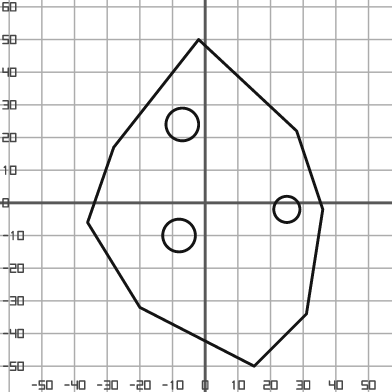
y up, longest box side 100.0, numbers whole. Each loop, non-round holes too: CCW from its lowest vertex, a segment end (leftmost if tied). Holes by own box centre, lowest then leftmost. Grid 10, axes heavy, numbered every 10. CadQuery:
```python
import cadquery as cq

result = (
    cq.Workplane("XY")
    .moveTo(15.0, -50.0)
    .lineTo(31.0, -34.0)
    .lineTo(36.0, -2.0)
    .lineTo(28.0, 22.0)
    .lineTo(-2.0, 50.0)
    .lineTo(-28.0, 17.0)
    .lineTo(-36.0, -6.0)
    .lineTo(-20.0, -32.0)
    .close()
    .moveTo(-8.0, -10.0)
    .circle(5.0)
    .moveTo(25.0, -2.0)
    .circle(4.0)
    .moveTo(-7.0, 24.0)
    .circle(5.0)
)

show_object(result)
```